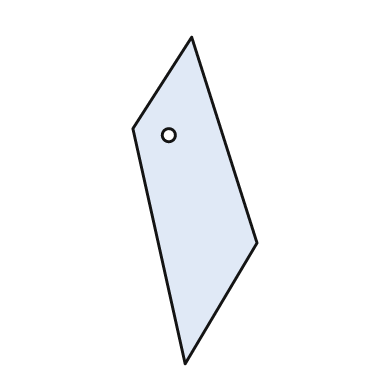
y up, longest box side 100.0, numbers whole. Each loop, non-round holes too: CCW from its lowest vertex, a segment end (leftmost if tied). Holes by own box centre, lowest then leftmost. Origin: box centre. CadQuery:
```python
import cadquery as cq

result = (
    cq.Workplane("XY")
    .moveTo(-3.0, -50.0)
    .lineTo(19.0, -13.0)
    .lineTo(-1.0, 50.0)
    .lineTo(-19.0, 22.0)
    .close()
    .moveTo(-8.0, 20.0)
    .circle(2.0)
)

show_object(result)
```